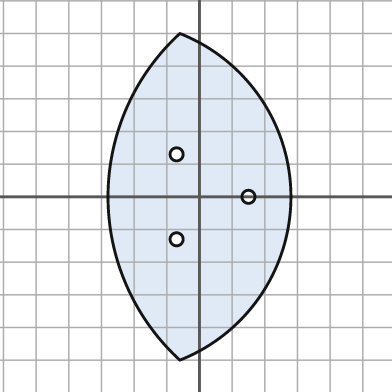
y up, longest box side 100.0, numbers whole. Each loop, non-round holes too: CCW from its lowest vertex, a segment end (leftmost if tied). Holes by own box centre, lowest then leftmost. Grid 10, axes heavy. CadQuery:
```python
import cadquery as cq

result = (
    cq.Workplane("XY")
    .moveTo(-6.0, -50.0)
    .threePointArc((28.0, 0.0), (-6.0, 50.0))
    .threePointArc((-28.0, 0.0), (-6.0, -50.0))
    .close()
    .moveTo(-7.0, -13.0)
    .circle(2.0)
    .moveTo(15.0, 0.0)
    .circle(2.0)
    .moveTo(-7.0, 13.0)
    .circle(2.0)
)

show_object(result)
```